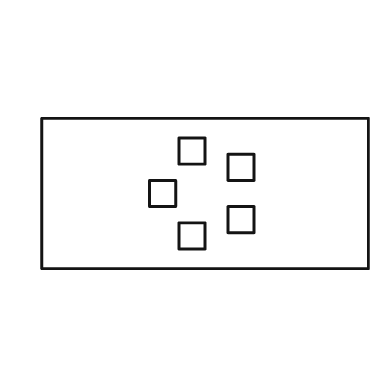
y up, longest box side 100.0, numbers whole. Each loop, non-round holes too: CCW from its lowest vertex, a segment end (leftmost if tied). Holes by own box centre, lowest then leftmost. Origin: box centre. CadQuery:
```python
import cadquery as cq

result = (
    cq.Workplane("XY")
    .moveTo(-50.0, -23.0)
    .lineTo(50.0, -23.0)
    .lineTo(50.0, 23.0)
    .lineTo(-50.0, 23.0)
    .close()
    .moveTo(-8.0, -17.0)
    .lineTo(0.0, -17.0)
    .lineTo(0.0, -9.0)
    .lineTo(-8.0, -9.0)
    .close()
    .moveTo(7.0, -12.0)
    .lineTo(15.0, -12.0)
    .lineTo(15.0, -4.0)
    .lineTo(7.0, -4.0)
    .close()
    .moveTo(-17.0, -4.0)
    .lineTo(-9.0, -4.0)
    .lineTo(-9.0, 4.0)
    .lineTo(-17.0, 4.0)
    .close()
    .moveTo(7.0, 4.0)
    .lineTo(15.0, 4.0)
    .lineTo(15.0, 12.0)
    .lineTo(7.0, 12.0)
    .close()
    .moveTo(-8.0, 9.0)
    .lineTo(0.0, 9.0)
    .lineTo(0.0, 17.0)
    .lineTo(-8.0, 17.0)
    .close()
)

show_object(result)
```